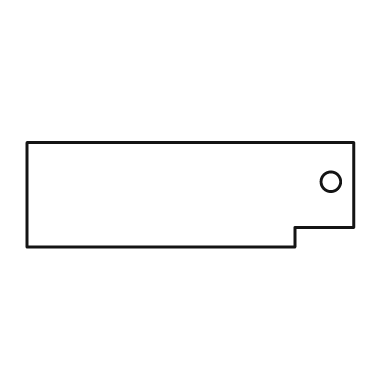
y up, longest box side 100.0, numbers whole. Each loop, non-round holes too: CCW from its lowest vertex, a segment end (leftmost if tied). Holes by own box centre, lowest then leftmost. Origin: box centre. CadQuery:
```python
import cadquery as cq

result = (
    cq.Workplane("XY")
    .moveTo(-50.0, -16.0)
    .lineTo(32.0, -16.0)
    .lineTo(32.0, -10.0)
    .lineTo(50.0, -10.0)
    .lineTo(50.0, 16.0)
    .lineTo(-50.0, 16.0)
    .close()
    .moveTo(43.0, 4.0)
    .circle(3.0)
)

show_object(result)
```